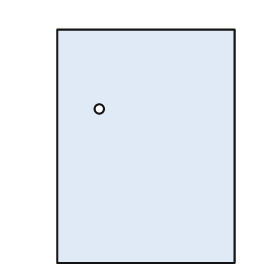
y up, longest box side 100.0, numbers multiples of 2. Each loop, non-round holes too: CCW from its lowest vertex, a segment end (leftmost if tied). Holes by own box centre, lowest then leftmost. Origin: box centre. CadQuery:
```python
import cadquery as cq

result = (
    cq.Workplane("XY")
    .moveTo(-38.0, -50.0)
    .lineTo(38.0, -50.0)
    .lineTo(38.0, 50.0)
    .lineTo(-38.0, 50.0)
    .close()
    .moveTo(-20.0, 16.0)
    .circle(2.0)
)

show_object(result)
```